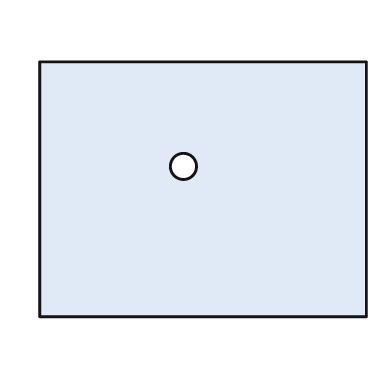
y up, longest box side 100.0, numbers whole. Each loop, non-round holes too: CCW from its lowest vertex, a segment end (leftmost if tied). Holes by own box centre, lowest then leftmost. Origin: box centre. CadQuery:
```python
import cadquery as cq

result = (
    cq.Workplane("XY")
    .moveTo(-50.0, -39.0)
    .lineTo(50.0, -39.0)
    .lineTo(50.0, 39.0)
    .lineTo(-50.0, 39.0)
    .close()
    .moveTo(-6.0, 7.0)
    .circle(4.0)
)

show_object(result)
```